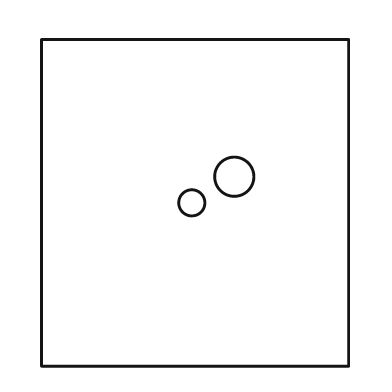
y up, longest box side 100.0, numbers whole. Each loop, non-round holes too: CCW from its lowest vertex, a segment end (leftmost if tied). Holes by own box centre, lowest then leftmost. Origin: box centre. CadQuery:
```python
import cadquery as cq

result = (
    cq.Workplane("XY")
    .moveTo(-47.0, -50.0)
    .lineTo(47.0, -50.0)
    .lineTo(47.0, 50.0)
    .lineTo(-47.0, 50.0)
    .close()
    .moveTo(-1.0, 0.0)
    .circle(4.0)
    .moveTo(12.0, 8.0)
    .circle(6.0)
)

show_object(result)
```